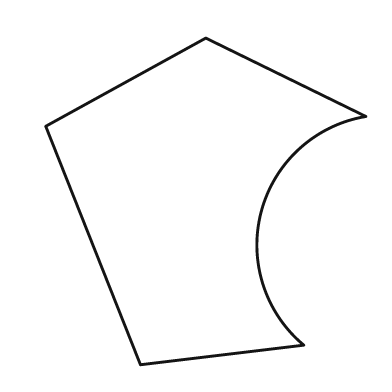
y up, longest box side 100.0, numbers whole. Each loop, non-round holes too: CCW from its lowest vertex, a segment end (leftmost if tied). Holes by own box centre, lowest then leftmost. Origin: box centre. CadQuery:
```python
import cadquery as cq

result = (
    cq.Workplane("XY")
    .moveTo(-20.0, -50.0)
    .lineTo(30.0, -44.0)
    .threePointArc((17.0, -3.0), (49.0, 26.0))
    .lineTo(0.0, 50.0)
    .lineTo(-49.0, 23.0)
    .close()
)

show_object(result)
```